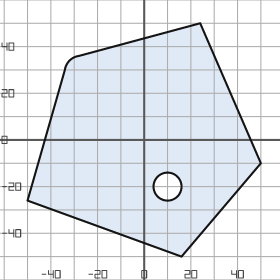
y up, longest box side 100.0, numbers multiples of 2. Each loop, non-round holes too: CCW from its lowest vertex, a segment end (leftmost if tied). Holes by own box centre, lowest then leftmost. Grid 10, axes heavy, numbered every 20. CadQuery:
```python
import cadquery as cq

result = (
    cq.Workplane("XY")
    .moveTo(16.0, -50.0)
    .lineTo(50.0, -10.0)
    .lineTo(24.0, 50.0)
    .lineTo(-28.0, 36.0)
    .threePointArc((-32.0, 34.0), (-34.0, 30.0))
    .lineTo(-50.0, -26.0)
    .close()
    .moveTo(10.0, -20.0)
    .circle(6.0)
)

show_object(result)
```